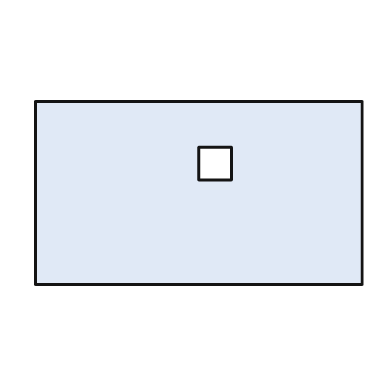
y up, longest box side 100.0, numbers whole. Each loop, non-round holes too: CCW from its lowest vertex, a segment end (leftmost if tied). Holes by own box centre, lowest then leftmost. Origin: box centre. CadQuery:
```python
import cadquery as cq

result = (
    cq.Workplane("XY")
    .moveTo(-50.0, -28.0)
    .lineTo(50.0, -28.0)
    .lineTo(50.0, 28.0)
    .lineTo(-50.0, 28.0)
    .close()
    .moveTo(0.0, 4.0)
    .lineTo(10.0, 4.0)
    .lineTo(10.0, 14.0)
    .lineTo(0.0, 14.0)
    .close()
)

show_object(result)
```